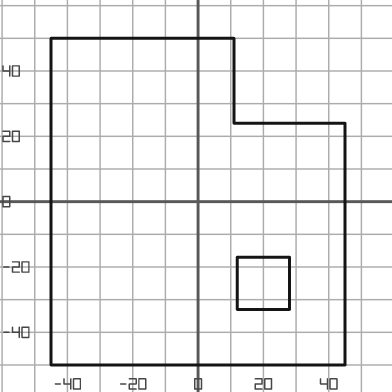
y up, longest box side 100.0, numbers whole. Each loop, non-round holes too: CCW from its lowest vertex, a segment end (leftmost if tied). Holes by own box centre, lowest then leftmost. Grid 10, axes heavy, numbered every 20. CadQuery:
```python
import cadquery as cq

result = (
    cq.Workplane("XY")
    .moveTo(-45.0, -50.0)
    .lineTo(45.0, -50.0)
    .lineTo(45.0, 24.0)
    .lineTo(11.0, 24.0)
    .lineTo(11.0, 50.0)
    .lineTo(-45.0, 50.0)
    .close()
    .moveTo(12.0, -33.0)
    .lineTo(28.0, -33.0)
    .lineTo(28.0, -17.0)
    .lineTo(12.0, -17.0)
    .close()
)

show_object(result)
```